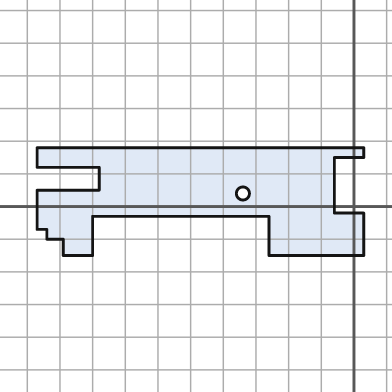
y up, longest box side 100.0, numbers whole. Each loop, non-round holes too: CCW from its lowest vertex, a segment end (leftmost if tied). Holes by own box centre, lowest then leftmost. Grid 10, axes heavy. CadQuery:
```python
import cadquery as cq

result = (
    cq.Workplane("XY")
    .moveTo(-89.0, -15.0)
    .lineTo(-80.0, -15.0)
    .lineTo(-80.0, -3.0)
    .lineTo(-26.0, -3.0)
    .lineTo(-26.0, -15.0)
    .lineTo(3.0, -15.0)
    .lineTo(3.0, -2.0)
    .lineTo(-6.0, -2.0)
    .lineTo(-6.0, 15.0)
    .lineTo(3.0, 15.0)
    .lineTo(3.0, 18.0)
    .lineTo(-97.0, 18.0)
    .lineTo(-97.0, 12.0)
    .lineTo(-78.0, 12.0)
    .lineTo(-78.0, 5.0)
    .lineTo(-97.0, 5.0)
    .lineTo(-97.0, -7.0)
    .lineTo(-94.0, -7.0)
    .lineTo(-94.0, -10.0)
    .lineTo(-89.0, -10.0)
    .close()
    .moveTo(-34.0, 4.0)
    .circle(2.0)
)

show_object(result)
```